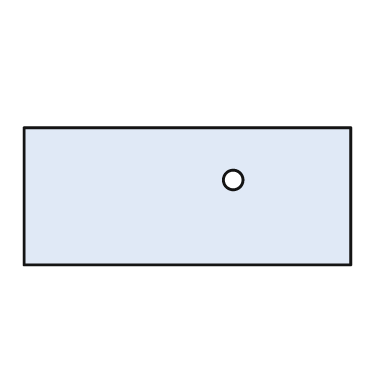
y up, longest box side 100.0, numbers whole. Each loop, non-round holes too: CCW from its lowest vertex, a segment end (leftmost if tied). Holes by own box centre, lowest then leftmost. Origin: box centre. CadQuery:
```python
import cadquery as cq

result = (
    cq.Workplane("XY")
    .moveTo(-50.0, -21.0)
    .lineTo(50.0, -21.0)
    .lineTo(50.0, 21.0)
    .lineTo(-50.0, 21.0)
    .close()
    .moveTo(14.0, 5.0)
    .circle(3.0)
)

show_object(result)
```